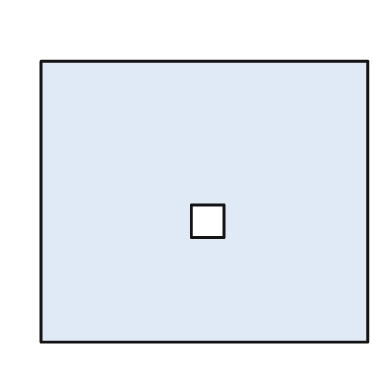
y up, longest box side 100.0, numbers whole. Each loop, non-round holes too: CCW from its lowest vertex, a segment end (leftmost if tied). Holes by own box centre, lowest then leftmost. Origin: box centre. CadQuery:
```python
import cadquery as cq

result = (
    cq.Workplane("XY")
    .moveTo(-50.0, -43.0)
    .lineTo(50.0, -43.0)
    .lineTo(50.0, 43.0)
    .lineTo(-50.0, 43.0)
    .close()
    .moveTo(-4.0, -11.0)
    .lineTo(6.0, -11.0)
    .lineTo(6.0, -1.0)
    .lineTo(-4.0, -1.0)
    .close()
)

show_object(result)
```